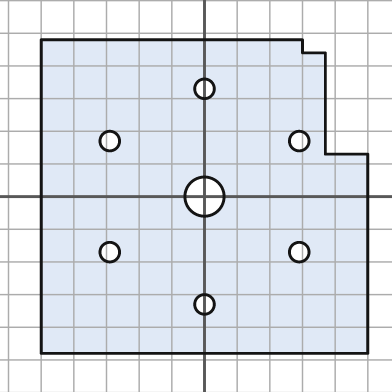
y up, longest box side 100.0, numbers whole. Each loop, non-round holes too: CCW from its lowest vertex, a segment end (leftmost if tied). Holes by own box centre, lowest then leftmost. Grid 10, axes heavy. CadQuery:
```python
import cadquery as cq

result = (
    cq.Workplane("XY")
    .moveTo(-50.0, -48.0)
    .lineTo(50.0, -48.0)
    .lineTo(50.0, 13.0)
    .lineTo(37.0, 13.0)
    .lineTo(37.0, 44.0)
    .lineTo(30.0, 44.0)
    .lineTo(30.0, 48.0)
    .lineTo(-50.0, 48.0)
    .close()
    .moveTo(0.0, -33.0)
    .circle(3.0)
    .moveTo(-29.0, -17.0)
    .circle(3.0)
    .moveTo(29.0, -17.0)
    .circle(3.0)
    .moveTo(0.0, 0.0)
    .circle(6.0)
    .moveTo(-29.0, 17.0)
    .circle(3.0)
    .moveTo(29.0, 17.0)
    .circle(3.0)
    .moveTo(0.0, 33.0)
    .circle(3.0)
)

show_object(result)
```